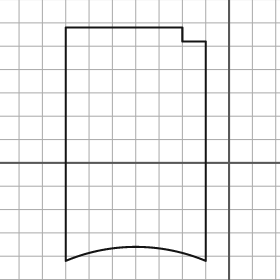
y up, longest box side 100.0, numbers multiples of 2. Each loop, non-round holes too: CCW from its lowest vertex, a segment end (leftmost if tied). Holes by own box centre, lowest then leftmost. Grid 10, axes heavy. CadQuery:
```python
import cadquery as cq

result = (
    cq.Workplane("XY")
    .moveTo(-70.0, -42.0)
    .threePointArc((-40.0, -36.0), (-10.0, -42.0))
    .lineTo(-10.0, 52.0)
    .lineTo(-20.0, 52.0)
    .lineTo(-20.0, 58.0)
    .lineTo(-70.0, 58.0)
    .close()
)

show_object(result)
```